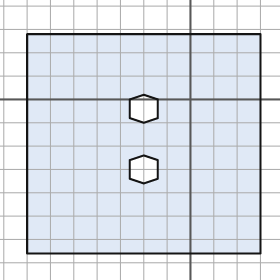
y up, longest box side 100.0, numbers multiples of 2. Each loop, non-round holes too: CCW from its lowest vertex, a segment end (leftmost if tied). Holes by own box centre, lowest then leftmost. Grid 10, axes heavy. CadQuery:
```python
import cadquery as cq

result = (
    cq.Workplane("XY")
    .moveTo(-70.0, -66.0)
    .lineTo(30.0, -66.0)
    .lineTo(30.0, 28.0)
    .lineTo(-70.0, 28.0)
    .close()
    .moveTo(-20.0, -36.0)
    .lineTo(-14.0, -34.0)
    .lineTo(-14.0, -26.0)
    .lineTo(-20.0, -24.0)
    .lineTo(-26.0, -26.0)
    .lineTo(-26.0, -34.0)
    .close()
    .moveTo(-20.0, -10.0)
    .lineTo(-14.0, -8.0)
    .lineTo(-14.0, 0.0)
    .lineTo(-20.0, 2.0)
    .lineTo(-26.0, 0.0)
    .lineTo(-26.0, -8.0)
    .close()
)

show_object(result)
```